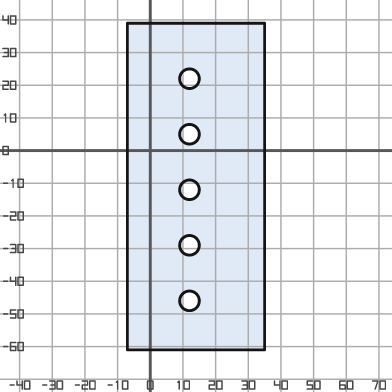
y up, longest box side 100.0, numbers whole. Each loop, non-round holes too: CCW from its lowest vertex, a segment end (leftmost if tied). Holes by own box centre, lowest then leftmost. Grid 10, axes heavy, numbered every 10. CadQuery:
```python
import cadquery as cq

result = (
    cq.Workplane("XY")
    .moveTo(-7.0, -61.0)
    .lineTo(35.0, -61.0)
    .lineTo(35.0, 39.0)
    .lineTo(-7.0, 39.0)
    .close()
    .moveTo(12.0, -46.0)
    .circle(3.0)
    .moveTo(12.0, -29.0)
    .circle(3.0)
    .moveTo(12.0, -12.0)
    .circle(3.0)
    .moveTo(12.0, 5.0)
    .circle(3.0)
    .moveTo(12.0, 22.0)
    .circle(3.0)
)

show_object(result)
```